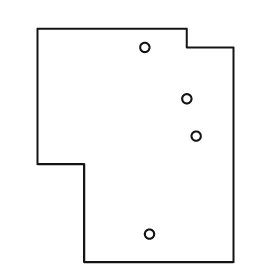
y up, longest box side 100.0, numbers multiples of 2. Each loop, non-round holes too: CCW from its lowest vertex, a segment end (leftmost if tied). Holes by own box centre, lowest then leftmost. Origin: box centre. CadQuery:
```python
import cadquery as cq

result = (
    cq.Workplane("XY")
    .moveTo(-22.0, -50.0)
    .lineTo(42.0, -50.0)
    .lineTo(42.0, 42.0)
    .lineTo(22.0, 42.0)
    .lineTo(22.0, 50.0)
    .lineTo(-42.0, 50.0)
    .lineTo(-42.0, -8.0)
    .lineTo(-22.0, -8.0)
    .close()
    .moveTo(6.0, -38.0)
    .circle(2.0)
    .moveTo(26.0, 4.0)
    .circle(2.0)
    .moveTo(22.0, 20.0)
    .circle(2.0)
    .moveTo(4.0, 42.0)
    .circle(2.0)
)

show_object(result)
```